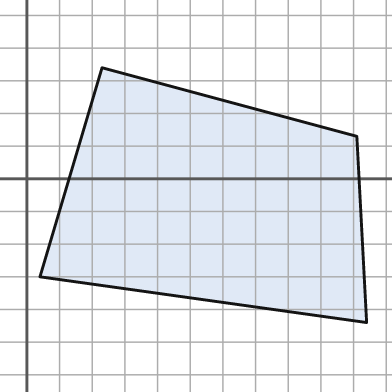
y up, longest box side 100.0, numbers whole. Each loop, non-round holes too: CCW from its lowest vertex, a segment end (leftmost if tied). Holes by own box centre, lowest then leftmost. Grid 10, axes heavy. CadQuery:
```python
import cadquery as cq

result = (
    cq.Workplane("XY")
    .moveTo(104.0, -44.0)
    .lineTo(101.0, 13.0)
    .lineTo(23.0, 34.0)
    .lineTo(4.0, -30.0)
    .close()
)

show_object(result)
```